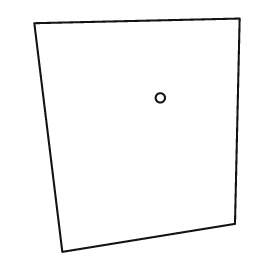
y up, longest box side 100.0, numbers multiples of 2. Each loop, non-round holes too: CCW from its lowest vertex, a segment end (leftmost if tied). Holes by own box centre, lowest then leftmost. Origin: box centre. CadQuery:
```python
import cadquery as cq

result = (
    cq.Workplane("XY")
    .moveTo(-32.0, -50.0)
    .lineTo(42.0, -38.0)
    .lineTo(44.0, 50.0)
    .lineTo(-44.0, 48.0)
    .close()
    .moveTo(10.0, 16.0)
    .circle(2.0)
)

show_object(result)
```